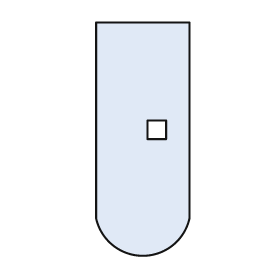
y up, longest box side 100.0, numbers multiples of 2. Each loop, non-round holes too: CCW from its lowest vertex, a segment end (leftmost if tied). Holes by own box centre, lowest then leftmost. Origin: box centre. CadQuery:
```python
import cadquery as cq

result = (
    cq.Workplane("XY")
    .moveTo(-20.0, -34.0)
    .threePointArc((0.0, -50.0), (20.0, -34.0))
    .lineTo(20.0, 50.0)
    .lineTo(-20.0, 50.0)
    .close()
    .moveTo(2.0, 0.0)
    .lineTo(10.0, 0.0)
    .lineTo(10.0, 8.0)
    .lineTo(2.0, 8.0)
    .close()
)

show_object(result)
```